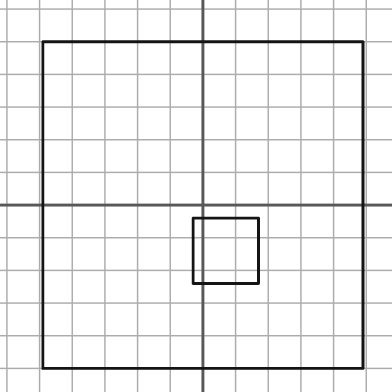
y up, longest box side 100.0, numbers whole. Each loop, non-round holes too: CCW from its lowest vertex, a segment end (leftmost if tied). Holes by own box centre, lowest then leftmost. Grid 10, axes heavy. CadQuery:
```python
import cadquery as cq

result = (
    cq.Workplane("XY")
    .moveTo(-49.0, -50.0)
    .lineTo(49.0, -50.0)
    .lineTo(49.0, 50.0)
    .lineTo(-49.0, 50.0)
    .close()
    .moveTo(-3.0, -24.0)
    .lineTo(17.0, -24.0)
    .lineTo(17.0, -4.0)
    .lineTo(-3.0, -4.0)
    .close()
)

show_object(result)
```